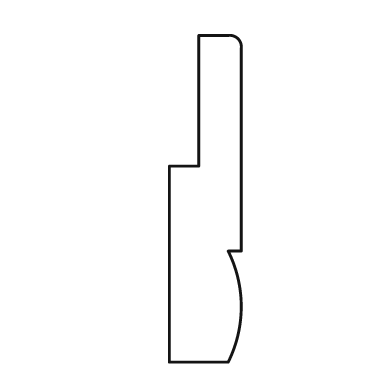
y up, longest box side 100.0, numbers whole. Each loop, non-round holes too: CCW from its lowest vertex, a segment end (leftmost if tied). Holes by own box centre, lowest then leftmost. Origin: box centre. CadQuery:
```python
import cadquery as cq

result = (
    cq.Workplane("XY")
    .moveTo(-11.0, -50.0)
    .lineTo(7.0, -50.0)
    .threePointArc((11.0, -33.0), (7.0, -16.0))
    .lineTo(11.0, -16.0)
    .lineTo(11.0, 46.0)
    .threePointArc((10.0, 49.0), (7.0, 50.0))
    .lineTo(-2.0, 50.0)
    .lineTo(-2.0, 10.0)
    .lineTo(-11.0, 10.0)
    .close()
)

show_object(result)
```